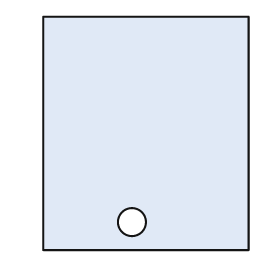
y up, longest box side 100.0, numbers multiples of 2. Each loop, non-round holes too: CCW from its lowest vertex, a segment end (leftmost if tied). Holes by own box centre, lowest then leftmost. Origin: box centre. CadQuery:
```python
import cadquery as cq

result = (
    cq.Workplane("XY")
    .moveTo(-44.0, -50.0)
    .lineTo(44.0, -50.0)
    .lineTo(44.0, 50.0)
    .lineTo(-44.0, 50.0)
    .close()
    .moveTo(-6.0, -38.0)
    .circle(6.0)
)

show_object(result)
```